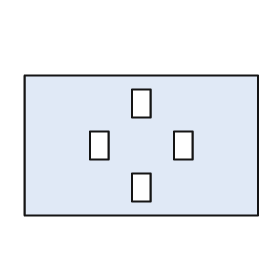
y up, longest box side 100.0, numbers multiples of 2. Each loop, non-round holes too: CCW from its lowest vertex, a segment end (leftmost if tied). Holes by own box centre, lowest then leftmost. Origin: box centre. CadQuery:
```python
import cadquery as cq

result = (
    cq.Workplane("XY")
    .moveTo(-50.0, -30.0)
    .lineTo(50.0, -30.0)
    .lineTo(50.0, 30.0)
    .lineTo(-50.0, 30.0)
    .close()
    .moveTo(-4.0, -24.0)
    .lineTo(4.0, -24.0)
    .lineTo(4.0, -12.0)
    .lineTo(-4.0, -12.0)
    .close()
    .moveTo(-22.0, -6.0)
    .lineTo(-14.0, -6.0)
    .lineTo(-14.0, 6.0)
    .lineTo(-22.0, 6.0)
    .close()
    .moveTo(14.0, -6.0)
    .lineTo(22.0, -6.0)
    .lineTo(22.0, 6.0)
    .lineTo(14.0, 6.0)
    .close()
    .moveTo(-4.0, 12.0)
    .lineTo(4.0, 12.0)
    .lineTo(4.0, 24.0)
    .lineTo(-4.0, 24.0)
    .close()
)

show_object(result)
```